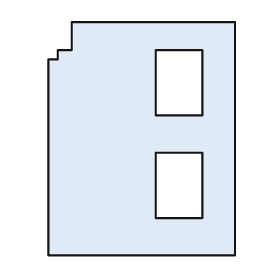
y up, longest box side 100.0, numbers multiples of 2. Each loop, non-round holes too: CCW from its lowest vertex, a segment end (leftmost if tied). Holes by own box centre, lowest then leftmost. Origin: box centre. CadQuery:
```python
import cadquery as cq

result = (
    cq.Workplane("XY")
    .moveTo(-40.0, -50.0)
    .lineTo(40.0, -50.0)
    .lineTo(40.0, 50.0)
    .lineTo(-30.0, 50.0)
    .lineTo(-30.0, 38.0)
    .lineTo(-36.0, 38.0)
    .lineTo(-36.0, 34.0)
    .lineTo(-40.0, 34.0)
    .close()
    .moveTo(6.0, -34.0)
    .lineTo(26.0, -34.0)
    .lineTo(26.0, -6.0)
    .lineTo(6.0, -6.0)
    .close()
    .moveTo(6.0, 10.0)
    .lineTo(26.0, 10.0)
    .lineTo(26.0, 38.0)
    .lineTo(6.0, 38.0)
    .close()
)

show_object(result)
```